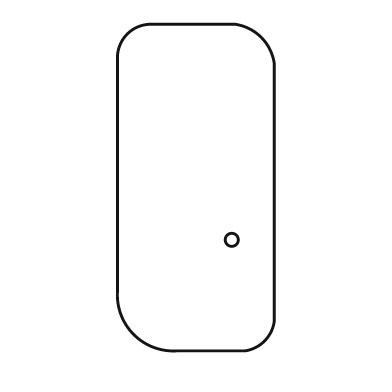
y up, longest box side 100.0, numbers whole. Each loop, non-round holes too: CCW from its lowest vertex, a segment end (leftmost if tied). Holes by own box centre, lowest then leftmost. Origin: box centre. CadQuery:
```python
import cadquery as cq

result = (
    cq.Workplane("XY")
    .moveTo(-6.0, -50.0)
    .lineTo(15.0, -50.0)
    .threePointArc((21.0, -47.0), (24.0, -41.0))
    .lineTo(24.0, 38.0)
    .threePointArc((20.0, 46.0), (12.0, 50.0))
    .lineTo(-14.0, 50.0)
    .threePointArc((-21.0, 47.0), (-24.0, 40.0))
    .lineTo(-24.0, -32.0)
    .threePointArc((-19.0, -45.0), (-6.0, -50.0))
    .close()
    .moveTo(11.0, -16.0)
    .circle(2.0)
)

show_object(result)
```